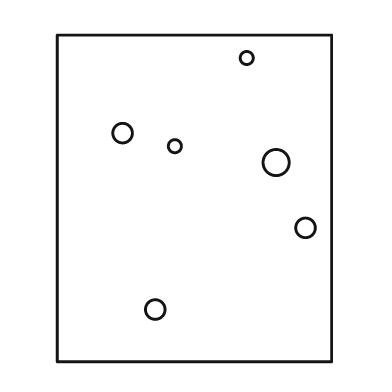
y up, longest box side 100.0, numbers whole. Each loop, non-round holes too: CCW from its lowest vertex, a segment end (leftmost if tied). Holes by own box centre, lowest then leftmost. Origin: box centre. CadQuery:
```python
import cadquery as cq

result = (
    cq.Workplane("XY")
    .moveTo(-42.0, -50.0)
    .lineTo(42.0, -50.0)
    .lineTo(42.0, 50.0)
    .lineTo(-42.0, 50.0)
    .close()
    .moveTo(-12.0, -34.0)
    .circle(3.0)
    .moveTo(34.0, -9.0)
    .circle(3.0)
    .moveTo(25.0, 11.0)
    .circle(4.0)
    .moveTo(-6.0, 16.0)
    .circle(2.0)
    .moveTo(-22.0, 20.0)
    .circle(3.0)
    .moveTo(16.0, 43.0)
    .circle(2.0)
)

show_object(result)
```